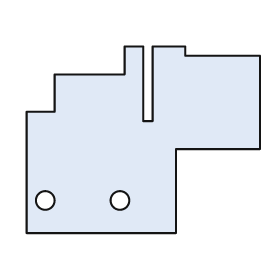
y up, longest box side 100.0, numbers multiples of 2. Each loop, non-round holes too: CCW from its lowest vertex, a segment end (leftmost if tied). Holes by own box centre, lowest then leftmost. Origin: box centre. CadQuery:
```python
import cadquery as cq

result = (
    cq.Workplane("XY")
    .moveTo(-50.0, -40.0)
    .lineTo(14.0, -40.0)
    .lineTo(14.0, -4.0)
    .lineTo(50.0, -4.0)
    .lineTo(50.0, 36.0)
    .lineTo(18.0, 36.0)
    .lineTo(18.0, 40.0)
    .lineTo(4.0, 40.0)
    .lineTo(4.0, 8.0)
    .lineTo(0.0, 8.0)
    .lineTo(0.0, 40.0)
    .lineTo(-8.0, 40.0)
    .lineTo(-8.0, 28.0)
    .lineTo(-38.0, 28.0)
    .lineTo(-38.0, 12.0)
    .lineTo(-50.0, 12.0)
    .close()
    .moveTo(-42.0, -26.0)
    .circle(4.0)
    .moveTo(-10.0, -26.0)
    .circle(4.0)
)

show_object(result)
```